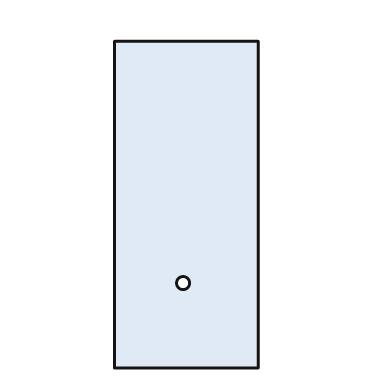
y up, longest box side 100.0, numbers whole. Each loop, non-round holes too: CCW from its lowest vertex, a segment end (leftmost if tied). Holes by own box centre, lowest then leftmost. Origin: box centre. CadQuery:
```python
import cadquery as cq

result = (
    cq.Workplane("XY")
    .moveTo(-22.0, -50.0)
    .lineTo(22.0, -50.0)
    .lineTo(22.0, 50.0)
    .lineTo(-22.0, 50.0)
    .close()
    .moveTo(-1.0, -24.0)
    .circle(2.0)
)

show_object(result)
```